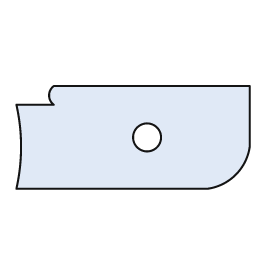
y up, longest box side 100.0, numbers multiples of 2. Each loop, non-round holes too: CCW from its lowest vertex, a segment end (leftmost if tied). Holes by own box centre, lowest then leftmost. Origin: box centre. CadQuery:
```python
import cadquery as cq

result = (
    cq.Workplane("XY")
    .moveTo(-50.0, -22.0)
    .lineTo(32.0, -22.0)
    .threePointArc((44.0, -16.0), (50.0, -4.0))
    .lineTo(50.0, 22.0)
    .lineTo(-34.0, 22.0)
    .threePointArc((-36.0, 18.0), (-34.0, 14.0))
    .lineTo(-50.0, 14.0)
    .threePointArc((-48.0, -4.0), (-50.0, -22.0))
    .close()
    .moveTo(6.0, 0.0)
    .circle(6.0)
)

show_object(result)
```